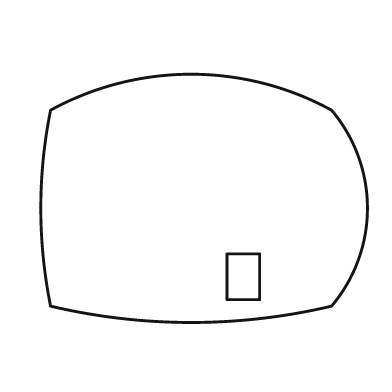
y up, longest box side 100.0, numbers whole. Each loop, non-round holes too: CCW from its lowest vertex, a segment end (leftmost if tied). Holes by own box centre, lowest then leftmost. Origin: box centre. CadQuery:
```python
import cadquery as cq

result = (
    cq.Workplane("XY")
    .moveTo(-47.0, -33.0)
    .threePointArc((-4.0, -38.0), (39.0, -33.0))
    .threePointArc((50.0, -3.0), (39.0, 27.0))
    .threePointArc((-4.0, 38.0), (-47.0, 27.0))
    .threePointArc((-50.0, -3.0), (-47.0, -33.0))
    .close()
    .moveTo(7.0, -31.0)
    .lineTo(17.0, -31.0)
    .lineTo(17.0, -17.0)
    .lineTo(7.0, -17.0)
    .close()
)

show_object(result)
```